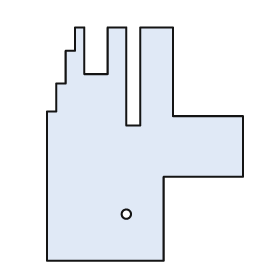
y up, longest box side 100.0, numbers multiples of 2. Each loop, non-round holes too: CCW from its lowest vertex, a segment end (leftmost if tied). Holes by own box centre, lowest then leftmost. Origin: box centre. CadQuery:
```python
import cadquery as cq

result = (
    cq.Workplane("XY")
    .moveTo(-42.0, -50.0)
    .lineTo(8.0, -50.0)
    .lineTo(8.0, -14.0)
    .lineTo(42.0, -14.0)
    .lineTo(42.0, 12.0)
    .lineTo(12.0, 12.0)
    .lineTo(12.0, 50.0)
    .lineTo(-2.0, 50.0)
    .lineTo(-2.0, 8.0)
    .lineTo(-8.0, 8.0)
    .lineTo(-8.0, 50.0)
    .lineTo(-16.0, 50.0)
    .lineTo(-16.0, 30.0)
    .lineTo(-26.0, 30.0)
    .lineTo(-26.0, 50.0)
    .lineTo(-30.0, 50.0)
    .lineTo(-30.0, 40.0)
    .lineTo(-34.0, 40.0)
    .lineTo(-34.0, 26.0)
    .lineTo(-38.0, 26.0)
    .lineTo(-38.0, 14.0)
    .lineTo(-42.0, 14.0)
    .close()
    .moveTo(-8.0, -30.0)
    .circle(2.0)
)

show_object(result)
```